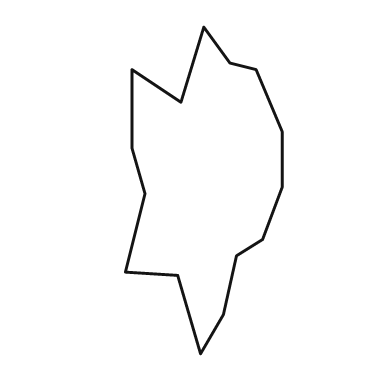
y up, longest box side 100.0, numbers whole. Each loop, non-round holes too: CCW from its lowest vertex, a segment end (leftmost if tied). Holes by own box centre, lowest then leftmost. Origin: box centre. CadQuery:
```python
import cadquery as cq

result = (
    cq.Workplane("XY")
    .moveTo(-1.0, -50.0)
    .lineTo(6.0, -38.0)
    .lineTo(10.0, -20.0)
    .lineTo(18.0, -15.0)
    .lineTo(24.0, 1.0)
    .lineTo(24.0, 18.0)
    .lineTo(16.0, 37.0)
    .lineTo(8.0, 39.0)
    .lineTo(0.0, 50.0)
    .lineTo(-7.0, 27.0)
    .lineTo(-22.0, 37.0)
    .lineTo(-22.0, 13.0)
    .lineTo(-18.0, -1.0)
    .lineTo(-24.0, -25.0)
    .lineTo(-8.0, -26.0)
    .close()
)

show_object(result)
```